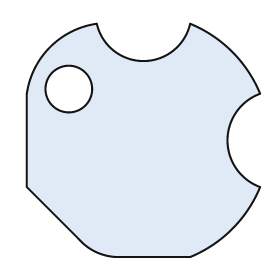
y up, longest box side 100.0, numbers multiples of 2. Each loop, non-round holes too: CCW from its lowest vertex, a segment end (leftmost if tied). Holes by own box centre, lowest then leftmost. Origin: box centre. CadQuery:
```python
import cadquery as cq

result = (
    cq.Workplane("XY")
    .moveTo(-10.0, -50.0)
    .lineTo(20.0, -50.0)
    .threePointArc((38.0, -38.0), (50.0, -20.0))
    .threePointArc((36.0, 0.0), (50.0, 20.0))
    .threePointArc((38.0, 38.0), (20.0, 50.0))
    .threePointArc((0.0, 34.0), (-20.0, 50.0))
    .threePointArc((-40.0, 40.0), (-50.0, 20.0))
    .lineTo(-50.0, -20.0)
    .lineTo(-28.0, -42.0)
    .threePointArc((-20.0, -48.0), (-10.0, -50.0))
    .close()
    .moveTo(-32.0, 22.0)
    .circle(10.0)
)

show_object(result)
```